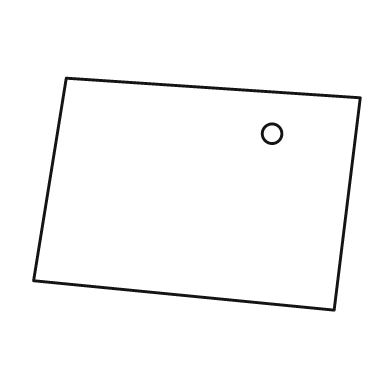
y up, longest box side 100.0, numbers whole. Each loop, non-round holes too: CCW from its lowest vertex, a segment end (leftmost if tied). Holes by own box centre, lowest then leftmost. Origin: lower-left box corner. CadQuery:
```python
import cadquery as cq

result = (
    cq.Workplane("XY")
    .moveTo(92.0, 0.0)
    .lineTo(100.0, 65.0)
    .lineTo(10.0, 71.0)
    .lineTo(0.0, 9.0)
    .close()
    .moveTo(73.0, 54.0)
    .circle(3.0)
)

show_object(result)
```